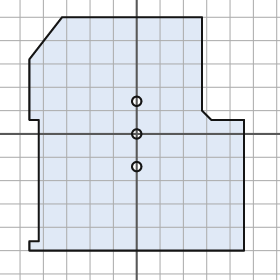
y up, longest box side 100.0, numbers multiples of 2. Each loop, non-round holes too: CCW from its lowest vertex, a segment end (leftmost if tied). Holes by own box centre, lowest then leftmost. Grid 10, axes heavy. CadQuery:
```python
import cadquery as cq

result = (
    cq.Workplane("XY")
    .moveTo(-46.0, -50.0)
    .lineTo(46.0, -50.0)
    .lineTo(46.0, 6.0)
    .lineTo(32.0, 6.0)
    .lineTo(28.0, 10.0)
    .lineTo(28.0, 50.0)
    .lineTo(-32.0, 50.0)
    .lineTo(-46.0, 32.0)
    .lineTo(-46.0, 6.0)
    .lineTo(-42.0, 6.0)
    .lineTo(-42.0, -46.0)
    .lineTo(-46.0, -46.0)
    .close()
    .moveTo(0.0, -14.0)
    .circle(2.0)
    .moveTo(0.0, 0.0)
    .circle(2.0)
    .moveTo(0.0, 14.0)
    .circle(2.0)
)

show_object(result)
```